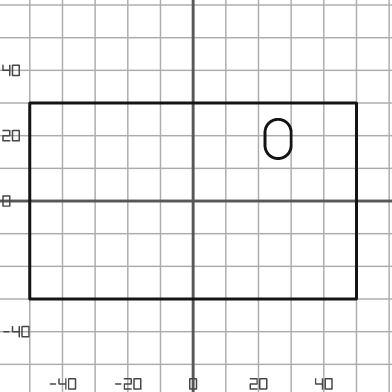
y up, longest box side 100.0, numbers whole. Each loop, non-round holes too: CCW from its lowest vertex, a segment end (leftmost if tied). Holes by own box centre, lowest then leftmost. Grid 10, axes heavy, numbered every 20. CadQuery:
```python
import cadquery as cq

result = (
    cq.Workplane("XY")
    .moveTo(-50.0, -30.0)
    .lineTo(50.0, -30.0)
    .lineTo(50.0, 30.0)
    .lineTo(-50.0, 30.0)
    .close()
    .moveTo(22.0, 17.0)
    .threePointArc((26.0, 13.0), (30.0, 17.0))
    .lineTo(30.0, 21.0)
    .threePointArc((26.0, 25.0), (22.0, 21.0))
    .close()
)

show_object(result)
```